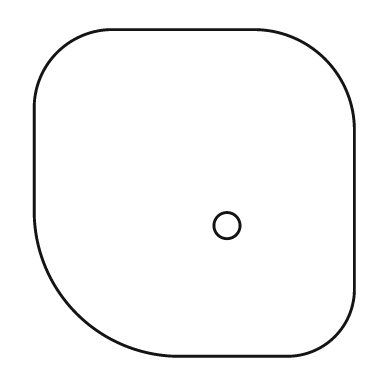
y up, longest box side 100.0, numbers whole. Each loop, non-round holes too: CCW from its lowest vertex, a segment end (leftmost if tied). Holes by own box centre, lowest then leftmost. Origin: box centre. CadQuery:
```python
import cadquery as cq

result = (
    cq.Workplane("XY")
    .moveTo(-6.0, -50.0)
    .lineTo(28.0, -50.0)
    .threePointArc((43.0, -44.0), (49.0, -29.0))
    .lineTo(49.0, 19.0)
    .threePointArc((40.0, 41.0), (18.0, 50.0))
    .lineTo(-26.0, 50.0)
    .threePointArc((-42.0, 43.0), (-49.0, 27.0))
    .lineTo(-49.0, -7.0)
    .threePointArc((-36.0, -37.0), (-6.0, -50.0))
    .close()
    .moveTo(10.0, -10.0)
    .circle(4.0)
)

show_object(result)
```